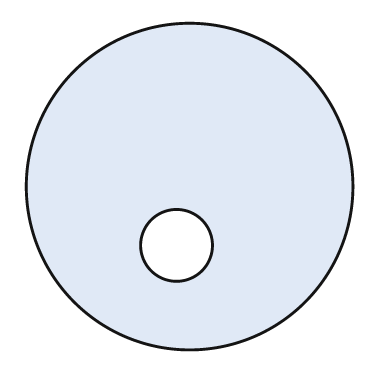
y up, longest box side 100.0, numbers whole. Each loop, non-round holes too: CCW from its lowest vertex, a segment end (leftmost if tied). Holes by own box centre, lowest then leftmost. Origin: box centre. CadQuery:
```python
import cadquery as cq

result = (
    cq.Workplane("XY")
    .moveTo(0.0, 0.0)
    .circle(50.0)
    .moveTo(-4.0, -18.0)
    .circle(11.0)
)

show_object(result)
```